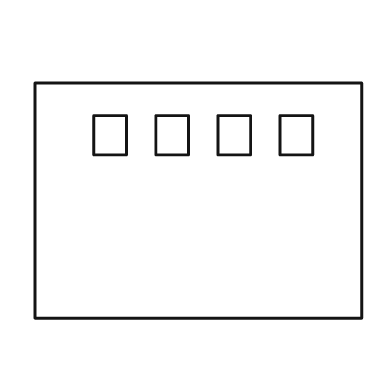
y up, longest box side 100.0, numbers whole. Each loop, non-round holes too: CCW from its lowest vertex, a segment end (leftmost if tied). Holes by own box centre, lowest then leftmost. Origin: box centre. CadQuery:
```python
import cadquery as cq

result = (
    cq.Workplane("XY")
    .moveTo(-50.0, -36.0)
    .lineTo(50.0, -36.0)
    .lineTo(50.0, 36.0)
    .lineTo(-50.0, 36.0)
    .close()
    .moveTo(-32.0, 14.0)
    .lineTo(-22.0, 14.0)
    .lineTo(-22.0, 26.0)
    .lineTo(-32.0, 26.0)
    .close()
    .moveTo(-13.0, 14.0)
    .lineTo(-3.0, 14.0)
    .lineTo(-3.0, 26.0)
    .lineTo(-13.0, 26.0)
    .close()
    .moveTo(6.0, 14.0)
    .lineTo(16.0, 14.0)
    .lineTo(16.0, 26.0)
    .lineTo(6.0, 26.0)
    .close()
    .moveTo(25.0, 14.0)
    .lineTo(35.0, 14.0)
    .lineTo(35.0, 26.0)
    .lineTo(25.0, 26.0)
    .close()
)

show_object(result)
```